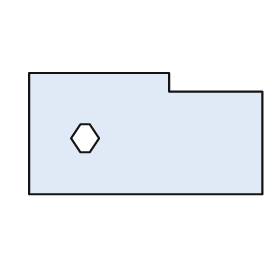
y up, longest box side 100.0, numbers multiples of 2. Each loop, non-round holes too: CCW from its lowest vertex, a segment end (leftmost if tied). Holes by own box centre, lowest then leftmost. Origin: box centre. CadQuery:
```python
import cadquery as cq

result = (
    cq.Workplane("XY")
    .moveTo(-50.0, -26.0)
    .lineTo(50.0, -26.0)
    .lineTo(50.0, 18.0)
    .lineTo(10.0, 18.0)
    .lineTo(10.0, 26.0)
    .lineTo(-50.0, 26.0)
    .close()
    .moveTo(-28.0, -8.0)
    .lineTo(-24.0, -8.0)
    .lineTo(-20.0, -2.0)
    .lineTo(-24.0, 4.0)
    .lineTo(-28.0, 4.0)
    .lineTo(-32.0, -2.0)
    .close()
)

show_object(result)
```